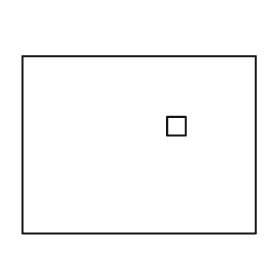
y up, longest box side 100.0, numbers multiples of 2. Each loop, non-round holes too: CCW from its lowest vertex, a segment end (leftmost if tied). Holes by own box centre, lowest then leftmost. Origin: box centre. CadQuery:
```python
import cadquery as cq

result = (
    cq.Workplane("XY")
    .moveTo(-50.0, -38.0)
    .lineTo(50.0, -38.0)
    .lineTo(50.0, 38.0)
    .lineTo(-50.0, 38.0)
    .close()
    .moveTo(12.0, 4.0)
    .lineTo(20.0, 4.0)
    .lineTo(20.0, 12.0)
    .lineTo(12.0, 12.0)
    .close()
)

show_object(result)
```